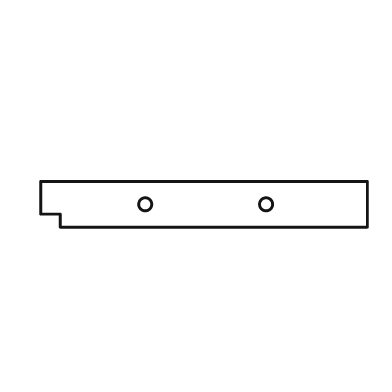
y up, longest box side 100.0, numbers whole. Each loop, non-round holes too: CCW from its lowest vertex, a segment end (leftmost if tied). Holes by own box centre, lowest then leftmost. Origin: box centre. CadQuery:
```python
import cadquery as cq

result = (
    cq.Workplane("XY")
    .moveTo(-44.0, -7.0)
    .lineTo(50.0, -7.0)
    .lineTo(50.0, 7.0)
    .lineTo(-50.0, 7.0)
    .lineTo(-50.0, -3.0)
    .lineTo(-44.0, -3.0)
    .close()
    .moveTo(-18.0, 0.0)
    .circle(2.0)
    .moveTo(19.0, 0.0)
    .circle(2.0)
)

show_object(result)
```